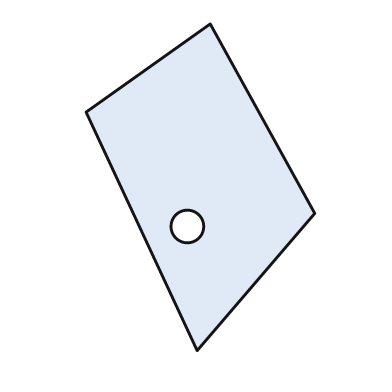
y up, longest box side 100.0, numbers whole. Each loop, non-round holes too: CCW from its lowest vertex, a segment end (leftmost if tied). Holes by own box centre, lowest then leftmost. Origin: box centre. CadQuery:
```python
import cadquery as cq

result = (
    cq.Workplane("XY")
    .moveTo(-1.0, -50.0)
    .lineTo(35.0, -8.0)
    .lineTo(3.0, 50.0)
    .lineTo(-35.0, 23.0)
    .close()
    .moveTo(-4.0, -12.0)
    .circle(5.0)
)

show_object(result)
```